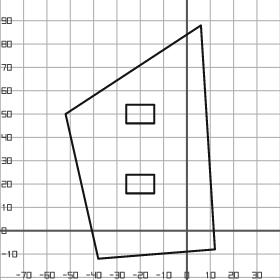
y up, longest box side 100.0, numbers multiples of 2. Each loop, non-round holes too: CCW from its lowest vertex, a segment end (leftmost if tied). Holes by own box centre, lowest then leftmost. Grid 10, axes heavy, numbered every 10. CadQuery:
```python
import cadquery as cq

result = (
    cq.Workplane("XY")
    .moveTo(-38.0, -12.0)
    .lineTo(12.0, -8.0)
    .lineTo(6.0, 88.0)
    .lineTo(-52.0, 50.0)
    .close()
    .moveTo(-26.0, 16.0)
    .lineTo(-14.0, 16.0)
    .lineTo(-14.0, 24.0)
    .lineTo(-26.0, 24.0)
    .close()
    .moveTo(-26.0, 46.0)
    .lineTo(-14.0, 46.0)
    .lineTo(-14.0, 54.0)
    .lineTo(-26.0, 54.0)
    .close()
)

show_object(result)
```